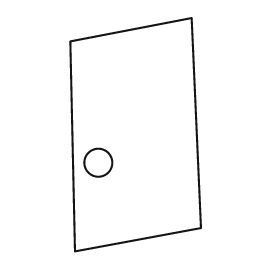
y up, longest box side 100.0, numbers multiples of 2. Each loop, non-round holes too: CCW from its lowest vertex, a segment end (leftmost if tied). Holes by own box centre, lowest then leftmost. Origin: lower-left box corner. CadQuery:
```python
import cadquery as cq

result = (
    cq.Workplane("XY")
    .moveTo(2.0, 0.0)
    .lineTo(56.0, 10.0)
    .lineTo(52.0, 100.0)
    .lineTo(0.0, 90.0)
    .close()
    .moveTo(12.0, 38.0)
    .circle(6.0)
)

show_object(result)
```